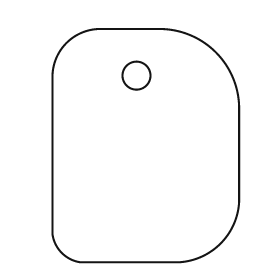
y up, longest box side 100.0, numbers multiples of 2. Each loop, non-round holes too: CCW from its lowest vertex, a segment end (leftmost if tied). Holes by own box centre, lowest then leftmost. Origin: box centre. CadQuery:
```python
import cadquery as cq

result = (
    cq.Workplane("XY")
    .moveTo(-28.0, -50.0)
    .lineTo(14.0, -50.0)
    .threePointArc((32.0, -42.0), (40.0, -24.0))
    .lineTo(40.0, 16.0)
    .threePointArc((30.0, 40.0), (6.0, 50.0))
    .lineTo(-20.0, 50.0)
    .threePointArc((-34.0, 44.0), (-40.0, 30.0))
    .lineTo(-40.0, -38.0)
    .threePointArc((-36.0, -46.0), (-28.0, -50.0))
    .close()
    .moveTo(-4.0, 30.0)
    .circle(6.0)
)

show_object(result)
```